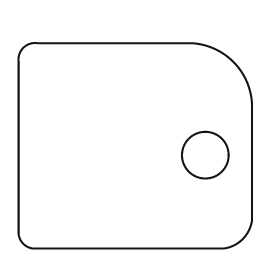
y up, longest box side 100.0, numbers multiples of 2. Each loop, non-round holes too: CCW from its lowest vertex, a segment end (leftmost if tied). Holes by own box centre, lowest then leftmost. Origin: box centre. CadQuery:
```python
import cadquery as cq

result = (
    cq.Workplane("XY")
    .moveTo(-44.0, -44.0)
    .lineTo(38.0, -44.0)
    .threePointArc((46.0, -40.0), (50.0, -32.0))
    .lineTo(50.0, 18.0)
    .threePointArc((42.0, 36.0), (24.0, 44.0))
    .lineTo(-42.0, 44.0)
    .threePointArc((-48.0, 42.0), (-50.0, 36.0))
    .lineTo(-50.0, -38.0)
    .threePointArc((-48.0, -42.0), (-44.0, -44.0))
    .close()
    .moveTo(30.0, -4.0)
    .circle(10.0)
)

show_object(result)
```